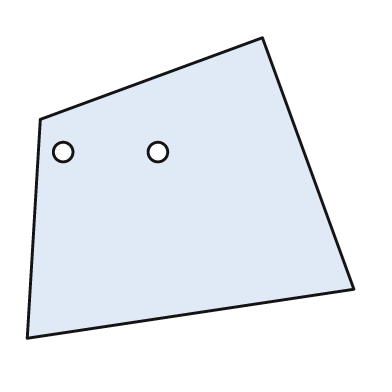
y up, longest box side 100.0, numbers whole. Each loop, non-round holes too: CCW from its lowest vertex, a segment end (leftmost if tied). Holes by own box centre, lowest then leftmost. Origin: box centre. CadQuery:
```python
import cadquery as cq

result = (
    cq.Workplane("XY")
    .moveTo(-50.0, -46.0)
    .lineTo(50.0, -31.0)
    .lineTo(22.0, 46.0)
    .lineTo(-46.0, 21.0)
    .close()
    .moveTo(-39.0, 11.0)
    .circle(3.0)
    .moveTo(-10.0, 11.0)
    .circle(3.0)
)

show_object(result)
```